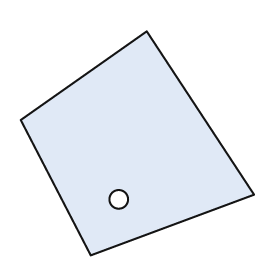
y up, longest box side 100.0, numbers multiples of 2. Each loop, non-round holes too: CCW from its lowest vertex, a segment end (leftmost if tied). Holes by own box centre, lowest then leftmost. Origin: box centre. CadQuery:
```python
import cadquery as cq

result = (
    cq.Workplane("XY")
    .moveTo(-20.0, -48.0)
    .lineTo(50.0, -22.0)
    .lineTo(4.0, 48.0)
    .lineTo(-50.0, 10.0)
    .close()
    .moveTo(-8.0, -24.0)
    .circle(4.0)
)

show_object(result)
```